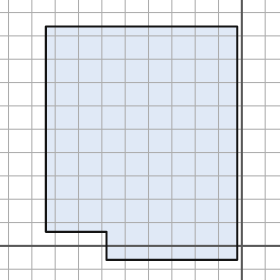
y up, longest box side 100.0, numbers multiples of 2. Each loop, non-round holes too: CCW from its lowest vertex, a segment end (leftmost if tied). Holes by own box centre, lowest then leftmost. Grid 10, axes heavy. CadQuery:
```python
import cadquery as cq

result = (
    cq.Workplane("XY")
    .moveTo(-58.0, -6.0)
    .lineTo(-2.0, -6.0)
    .lineTo(-2.0, 94.0)
    .lineTo(-84.0, 94.0)
    .lineTo(-84.0, 6.0)
    .lineTo(-58.0, 6.0)
    .close()
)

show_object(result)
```